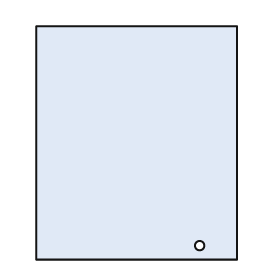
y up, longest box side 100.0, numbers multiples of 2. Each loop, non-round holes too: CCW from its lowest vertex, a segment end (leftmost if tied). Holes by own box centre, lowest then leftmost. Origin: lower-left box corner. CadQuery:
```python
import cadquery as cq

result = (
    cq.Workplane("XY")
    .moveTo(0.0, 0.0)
    .lineTo(86.0, 0.0)
    .lineTo(86.0, 100.0)
    .lineTo(0.0, 100.0)
    .close()
    .moveTo(70.0, 6.0)
    .circle(2.0)
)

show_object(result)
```